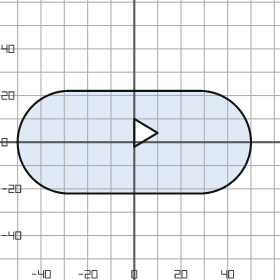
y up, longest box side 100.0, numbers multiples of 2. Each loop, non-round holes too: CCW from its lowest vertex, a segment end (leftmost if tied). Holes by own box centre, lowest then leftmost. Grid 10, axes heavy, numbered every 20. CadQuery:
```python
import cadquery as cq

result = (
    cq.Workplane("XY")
    .moveTo(-28.0, -22.0)
    .lineTo(28.0, -22.0)
    .threePointArc((50.0, 0.0), (28.0, 22.0))
    .lineTo(-28.0, 22.0)
    .threePointArc((-50.0, 0.0), (-28.0, -22.0))
    .close()
    .moveTo(0.0, -2.0)
    .lineTo(10.0, 4.0)
    .lineTo(0.0, 10.0)
    .close()
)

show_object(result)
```